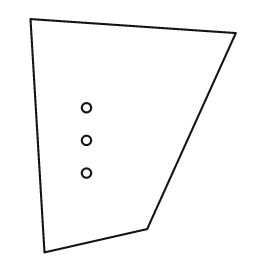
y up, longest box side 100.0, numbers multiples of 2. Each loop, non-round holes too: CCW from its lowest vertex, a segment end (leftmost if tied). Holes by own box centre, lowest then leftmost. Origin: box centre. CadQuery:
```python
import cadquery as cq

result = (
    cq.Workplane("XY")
    .moveTo(-38.0, -50.0)
    .lineTo(6.0, -40.0)
    .lineTo(44.0, 44.0)
    .lineTo(-44.0, 50.0)
    .close()
    .moveTo(-20.0, -16.0)
    .circle(2.0)
    .moveTo(-20.0, -2.0)
    .circle(2.0)
    .moveTo(-20.0, 12.0)
    .circle(2.0)
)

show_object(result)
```